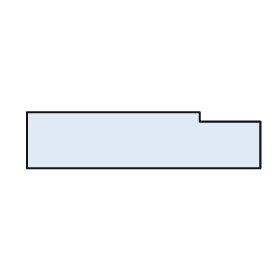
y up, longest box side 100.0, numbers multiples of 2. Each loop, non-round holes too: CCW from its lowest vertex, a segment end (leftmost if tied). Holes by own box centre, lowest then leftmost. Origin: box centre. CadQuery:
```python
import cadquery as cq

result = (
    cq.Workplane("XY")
    .moveTo(-50.0, -12.0)
    .lineTo(50.0, -12.0)
    .lineTo(50.0, 8.0)
    .lineTo(24.0, 8.0)
    .lineTo(24.0, 12.0)
    .lineTo(-50.0, 12.0)
    .close()
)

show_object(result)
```